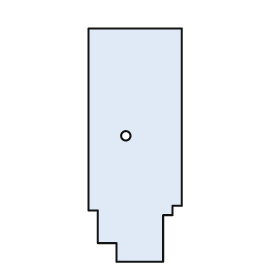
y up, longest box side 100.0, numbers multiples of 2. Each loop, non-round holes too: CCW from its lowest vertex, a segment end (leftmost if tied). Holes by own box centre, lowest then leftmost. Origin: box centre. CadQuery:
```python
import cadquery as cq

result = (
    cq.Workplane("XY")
    .moveTo(-8.0, -50.0)
    .lineTo(12.0, -50.0)
    .lineTo(12.0, -30.0)
    .lineTo(16.0, -30.0)
    .lineTo(16.0, -26.0)
    .lineTo(20.0, -26.0)
    .lineTo(20.0, 50.0)
    .lineTo(-20.0, 50.0)
    .lineTo(-20.0, -28.0)
    .lineTo(-16.0, -28.0)
    .lineTo(-16.0, -42.0)
    .lineTo(-8.0, -42.0)
    .close()
    .moveTo(-4.0, 4.0)
    .circle(2.0)
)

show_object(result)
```